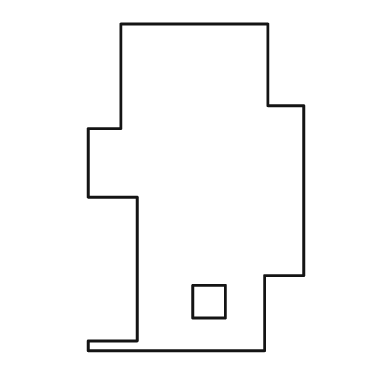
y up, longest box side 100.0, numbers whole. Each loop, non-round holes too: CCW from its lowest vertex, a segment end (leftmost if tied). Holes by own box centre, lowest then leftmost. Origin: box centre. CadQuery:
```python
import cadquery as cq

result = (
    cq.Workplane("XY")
    .moveTo(-33.0, -50.0)
    .lineTo(21.0, -50.0)
    .lineTo(21.0, -27.0)
    .lineTo(33.0, -27.0)
    .lineTo(33.0, 25.0)
    .lineTo(22.0, 25.0)
    .lineTo(22.0, 50.0)
    .lineTo(-23.0, 50.0)
    .lineTo(-23.0, 18.0)
    .lineTo(-33.0, 18.0)
    .lineTo(-33.0, -3.0)
    .lineTo(-18.0, -3.0)
    .lineTo(-18.0, -47.0)
    .lineTo(-33.0, -47.0)
    .close()
    .moveTo(-1.0, -40.0)
    .lineTo(9.0, -40.0)
    .lineTo(9.0, -30.0)
    .lineTo(-1.0, -30.0)
    .close()
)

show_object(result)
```